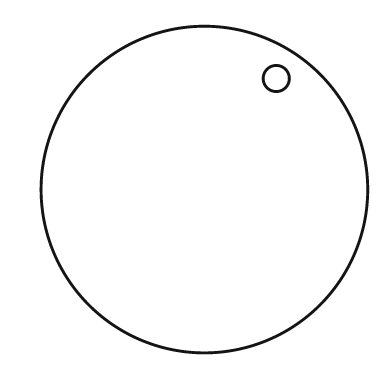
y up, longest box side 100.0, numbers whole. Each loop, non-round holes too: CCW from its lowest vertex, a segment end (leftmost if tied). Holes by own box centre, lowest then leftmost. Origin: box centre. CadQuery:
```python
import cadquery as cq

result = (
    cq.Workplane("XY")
    .moveTo(0.0, 0.0)
    .circle(50.0)
    .moveTo(22.0, 34.0)
    .circle(4.0)
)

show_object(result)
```